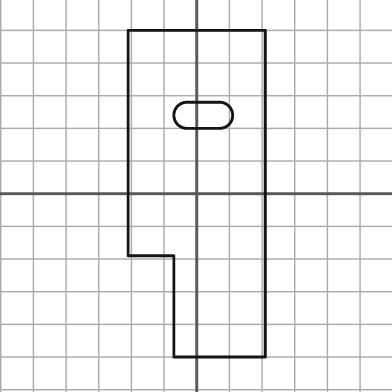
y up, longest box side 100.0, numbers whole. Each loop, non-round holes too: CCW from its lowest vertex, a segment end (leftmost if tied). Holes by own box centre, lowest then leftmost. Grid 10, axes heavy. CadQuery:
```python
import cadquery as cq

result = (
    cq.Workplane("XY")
    .moveTo(-7.0, -50.0)
    .lineTo(21.0, -50.0)
    .lineTo(21.0, 50.0)
    .lineTo(-21.0, 50.0)
    .lineTo(-21.0, -19.0)
    .lineTo(-7.0, -19.0)
    .close()
    .moveTo(-3.0, 20.0)
    .lineTo(7.0, 20.0)
    .threePointArc((11.0, 24.0), (7.0, 28.0))
    .lineTo(-3.0, 28.0)
    .threePointArc((-7.0, 24.0), (-3.0, 20.0))
    .close()
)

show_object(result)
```